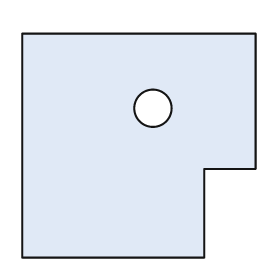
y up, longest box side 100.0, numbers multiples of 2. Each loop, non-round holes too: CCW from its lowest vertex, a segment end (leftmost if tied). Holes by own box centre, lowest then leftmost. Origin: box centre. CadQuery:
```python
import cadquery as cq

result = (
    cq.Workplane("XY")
    .moveTo(-50.0, -48.0)
    .lineTo(28.0, -48.0)
    .lineTo(28.0, -10.0)
    .lineTo(50.0, -10.0)
    .lineTo(50.0, 48.0)
    .lineTo(-50.0, 48.0)
    .close()
    .moveTo(6.0, 16.0)
    .circle(8.0)
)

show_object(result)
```